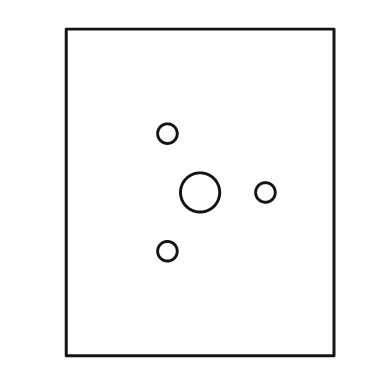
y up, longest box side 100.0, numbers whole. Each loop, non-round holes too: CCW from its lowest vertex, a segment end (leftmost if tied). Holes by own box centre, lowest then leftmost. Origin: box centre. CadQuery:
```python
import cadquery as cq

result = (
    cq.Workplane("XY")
    .moveTo(-41.0, -50.0)
    .lineTo(41.0, -50.0)
    .lineTo(41.0, 50.0)
    .lineTo(-41.0, 50.0)
    .close()
    .moveTo(-10.0, -18.0)
    .circle(3.0)
    .moveTo(0.0, 0.0)
    .circle(6.0)
    .moveTo(20.0, 0.0)
    .circle(3.0)
    .moveTo(-10.0, 18.0)
    .circle(3.0)
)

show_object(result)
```